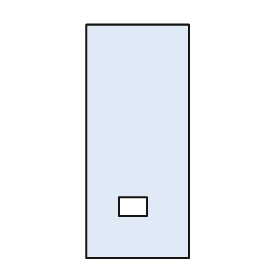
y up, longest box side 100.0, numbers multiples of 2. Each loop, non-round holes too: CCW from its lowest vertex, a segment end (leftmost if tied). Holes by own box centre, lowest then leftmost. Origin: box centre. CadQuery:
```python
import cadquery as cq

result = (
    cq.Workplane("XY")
    .moveTo(-22.0, -50.0)
    .lineTo(22.0, -50.0)
    .lineTo(22.0, 50.0)
    .lineTo(-22.0, 50.0)
    .close()
    .moveTo(-8.0, -32.0)
    .lineTo(4.0, -32.0)
    .lineTo(4.0, -24.0)
    .lineTo(-8.0, -24.0)
    .close()
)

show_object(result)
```